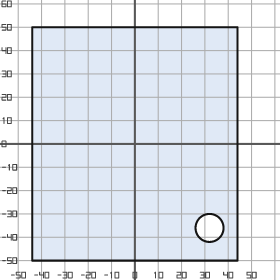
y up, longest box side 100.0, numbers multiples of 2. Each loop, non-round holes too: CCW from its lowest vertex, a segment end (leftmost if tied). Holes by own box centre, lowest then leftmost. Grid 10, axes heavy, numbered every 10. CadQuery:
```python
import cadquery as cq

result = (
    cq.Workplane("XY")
    .moveTo(-44.0, -50.0)
    .lineTo(44.0, -50.0)
    .lineTo(44.0, 50.0)
    .lineTo(-44.0, 50.0)
    .close()
    .moveTo(32.0, -36.0)
    .circle(6.0)
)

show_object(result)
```